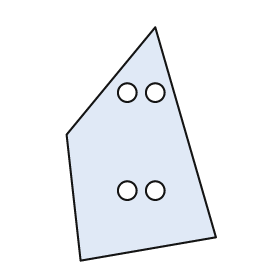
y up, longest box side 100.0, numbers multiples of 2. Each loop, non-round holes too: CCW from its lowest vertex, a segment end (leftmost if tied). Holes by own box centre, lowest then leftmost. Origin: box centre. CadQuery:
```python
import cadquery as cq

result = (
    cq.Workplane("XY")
    .moveTo(-26.0, -50.0)
    .lineTo(32.0, -40.0)
    .lineTo(6.0, 50.0)
    .lineTo(-32.0, 4.0)
    .close()
    .moveTo(-6.0, -20.0)
    .circle(4.0)
    .moveTo(6.0, -20.0)
    .circle(4.0)
    .moveTo(-6.0, 22.0)
    .circle(4.0)
    .moveTo(6.0, 22.0)
    .circle(4.0)
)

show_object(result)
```